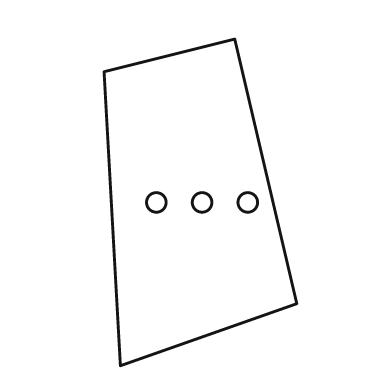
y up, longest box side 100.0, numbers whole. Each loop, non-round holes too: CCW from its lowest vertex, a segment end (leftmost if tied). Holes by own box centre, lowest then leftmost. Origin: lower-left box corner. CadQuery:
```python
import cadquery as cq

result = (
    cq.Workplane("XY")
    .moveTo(5.0, 0.0)
    .lineTo(59.0, 19.0)
    .lineTo(40.0, 100.0)
    .lineTo(0.0, 90.0)
    .close()
    .moveTo(16.0, 50.0)
    .circle(3.0)
    .moveTo(30.0, 50.0)
    .circle(3.0)
    .moveTo(44.0, 50.0)
    .circle(3.0)
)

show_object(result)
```